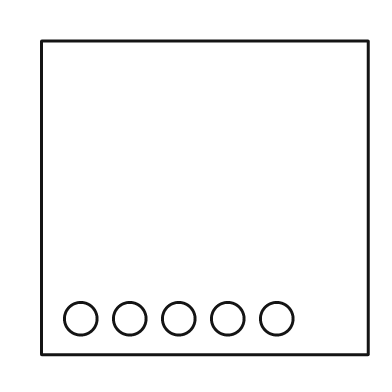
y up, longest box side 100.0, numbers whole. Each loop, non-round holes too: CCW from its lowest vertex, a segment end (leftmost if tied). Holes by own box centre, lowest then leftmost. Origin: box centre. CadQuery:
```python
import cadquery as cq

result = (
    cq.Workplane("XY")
    .moveTo(-50.0, -48.0)
    .lineTo(50.0, -48.0)
    .lineTo(50.0, 48.0)
    .lineTo(-50.0, 48.0)
    .close()
    .moveTo(-38.0, -37.0)
    .circle(5.0)
    .moveTo(-23.0, -37.0)
    .circle(5.0)
    .moveTo(-8.0, -37.0)
    .circle(5.0)
    .moveTo(7.0, -37.0)
    .circle(5.0)
    .moveTo(22.0, -37.0)
    .circle(5.0)
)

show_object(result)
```